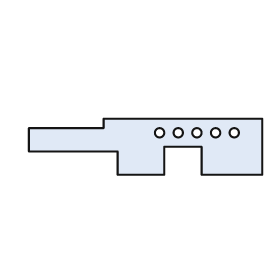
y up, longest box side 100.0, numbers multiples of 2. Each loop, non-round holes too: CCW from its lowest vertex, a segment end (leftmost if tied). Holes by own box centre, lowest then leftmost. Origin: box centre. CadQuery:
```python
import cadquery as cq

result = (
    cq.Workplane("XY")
    .moveTo(-12.0, -12.0)
    .lineTo(8.0, -12.0)
    .lineTo(8.0, 0.0)
    .lineTo(24.0, 0.0)
    .lineTo(24.0, -12.0)
    .lineTo(50.0, -12.0)
    .lineTo(50.0, 12.0)
    .lineTo(-18.0, 12.0)
    .lineTo(-18.0, 8.0)
    .lineTo(-50.0, 8.0)
    .lineTo(-50.0, -2.0)
    .lineTo(-12.0, -2.0)
    .close()
    .moveTo(6.0, 6.0)
    .circle(2.0)
    .moveTo(14.0, 6.0)
    .circle(2.0)
    .moveTo(22.0, 6.0)
    .circle(2.0)
    .moveTo(30.0, 6.0)
    .circle(2.0)
    .moveTo(38.0, 6.0)
    .circle(2.0)
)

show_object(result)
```